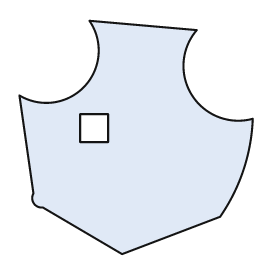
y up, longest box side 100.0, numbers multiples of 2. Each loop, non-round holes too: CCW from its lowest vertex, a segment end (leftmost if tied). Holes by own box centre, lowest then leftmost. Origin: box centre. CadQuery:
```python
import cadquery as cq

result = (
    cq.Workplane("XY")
    .moveTo(-6.0, -50.0)
    .lineTo(36.0, -34.0)
    .threePointArc((46.0, -14.0), (50.0, 8.0))
    .threePointArc((24.0, 18.0), (26.0, 46.0))
    .lineTo(-20.0, 50.0)
    .threePointArc((-22.0, 22.0), (-50.0, 18.0))
    .lineTo(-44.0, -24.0)
    .threePointArc((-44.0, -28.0), (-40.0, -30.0))
    .close()
    .moveTo(-24.0, -2.0)
    .lineTo(-12.0, -2.0)
    .lineTo(-12.0, 10.0)
    .lineTo(-24.0, 10.0)
    .close()
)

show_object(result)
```